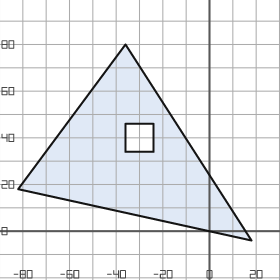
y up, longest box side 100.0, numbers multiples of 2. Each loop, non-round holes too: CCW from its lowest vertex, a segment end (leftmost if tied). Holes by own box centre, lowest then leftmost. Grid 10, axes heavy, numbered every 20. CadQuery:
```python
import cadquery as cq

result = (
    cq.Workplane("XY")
    .moveTo(18.0, -4.0)
    .lineTo(-36.0, 80.0)
    .lineTo(-82.0, 18.0)
    .close()
    .moveTo(-36.0, 34.0)
    .lineTo(-24.0, 34.0)
    .lineTo(-24.0, 46.0)
    .lineTo(-36.0, 46.0)
    .close()
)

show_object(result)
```